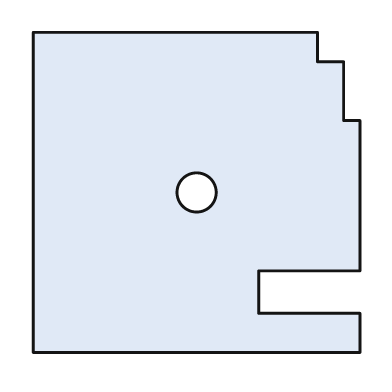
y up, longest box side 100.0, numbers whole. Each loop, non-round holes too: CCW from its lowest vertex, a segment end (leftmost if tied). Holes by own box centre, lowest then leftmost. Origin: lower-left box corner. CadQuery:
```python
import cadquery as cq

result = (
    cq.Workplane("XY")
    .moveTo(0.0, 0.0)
    .lineTo(100.0, 0.0)
    .lineTo(100.0, 12.0)
    .lineTo(69.0, 12.0)
    .lineTo(69.0, 25.0)
    .lineTo(100.0, 25.0)
    .lineTo(100.0, 71.0)
    .lineTo(95.0, 71.0)
    .lineTo(95.0, 89.0)
    .lineTo(87.0, 89.0)
    .lineTo(87.0, 98.0)
    .lineTo(0.0, 98.0)
    .close()
    .moveTo(50.0, 49.0)
    .circle(6.0)
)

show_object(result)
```